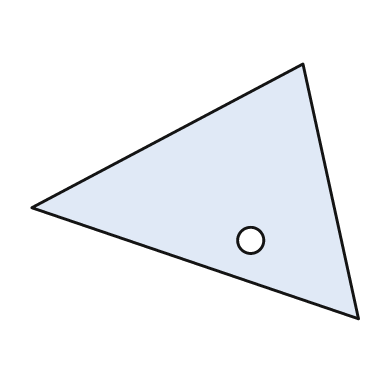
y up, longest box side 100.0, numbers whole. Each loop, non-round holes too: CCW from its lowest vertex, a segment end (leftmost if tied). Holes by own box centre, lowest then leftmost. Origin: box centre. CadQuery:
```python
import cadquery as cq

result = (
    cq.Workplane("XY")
    .moveTo(50.0, -39.0)
    .lineTo(33.0, 39.0)
    .lineTo(-50.0, -5.0)
    .close()
    .moveTo(17.0, -15.0)
    .circle(4.0)
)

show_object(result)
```